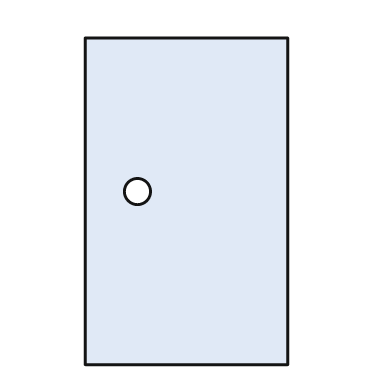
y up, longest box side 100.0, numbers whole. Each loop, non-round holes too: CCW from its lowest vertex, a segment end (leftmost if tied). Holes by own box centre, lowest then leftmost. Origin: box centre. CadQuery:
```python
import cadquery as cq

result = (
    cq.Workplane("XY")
    .moveTo(-31.0, -50.0)
    .lineTo(31.0, -50.0)
    .lineTo(31.0, 50.0)
    .lineTo(-31.0, 50.0)
    .close()
    .moveTo(-15.0, 3.0)
    .circle(4.0)
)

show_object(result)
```